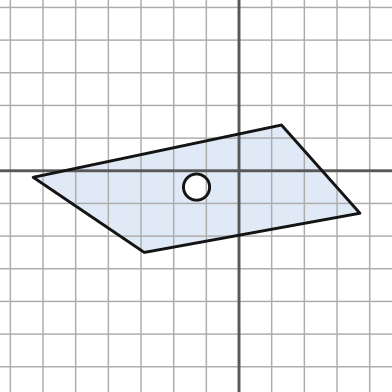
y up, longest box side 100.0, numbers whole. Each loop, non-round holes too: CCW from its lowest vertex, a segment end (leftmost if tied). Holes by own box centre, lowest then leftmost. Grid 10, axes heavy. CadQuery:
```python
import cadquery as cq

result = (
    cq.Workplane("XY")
    .moveTo(-29.0, -25.0)
    .lineTo(37.0, -13.0)
    .lineTo(13.0, 14.0)
    .lineTo(-63.0, -2.0)
    .close()
    .moveTo(-13.0, -5.0)
    .circle(4.0)
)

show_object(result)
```